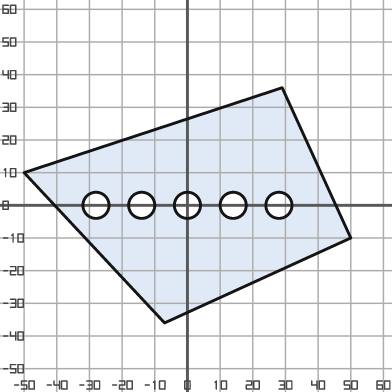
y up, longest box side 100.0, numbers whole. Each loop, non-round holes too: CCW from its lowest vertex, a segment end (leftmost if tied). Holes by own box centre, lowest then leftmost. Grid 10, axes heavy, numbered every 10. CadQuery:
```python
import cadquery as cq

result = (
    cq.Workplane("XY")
    .moveTo(-7.0, -36.0)
    .lineTo(50.0, -10.0)
    .lineTo(29.0, 36.0)
    .lineTo(-50.0, 10.0)
    .close()
    .moveTo(-28.0, 0.0)
    .circle(4.0)
    .moveTo(-14.0, 0.0)
    .circle(4.0)
    .moveTo(0.0, 0.0)
    .circle(4.0)
    .moveTo(14.0, 0.0)
    .circle(4.0)
    .moveTo(28.0, 0.0)
    .circle(4.0)
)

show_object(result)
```